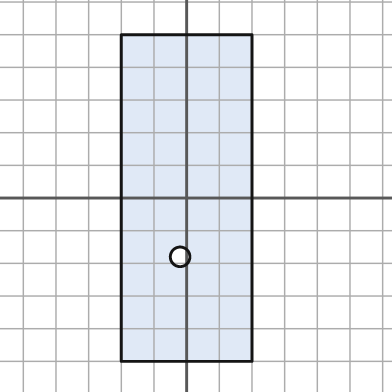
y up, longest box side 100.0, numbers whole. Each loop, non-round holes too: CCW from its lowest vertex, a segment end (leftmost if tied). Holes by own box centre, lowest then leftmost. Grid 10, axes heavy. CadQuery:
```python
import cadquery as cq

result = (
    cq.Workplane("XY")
    .moveTo(-20.0, -50.0)
    .lineTo(20.0, -50.0)
    .lineTo(20.0, 50.0)
    .lineTo(-20.0, 50.0)
    .close()
    .moveTo(-2.0, -18.0)
    .circle(3.0)
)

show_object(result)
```